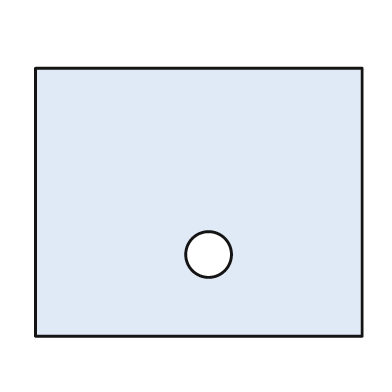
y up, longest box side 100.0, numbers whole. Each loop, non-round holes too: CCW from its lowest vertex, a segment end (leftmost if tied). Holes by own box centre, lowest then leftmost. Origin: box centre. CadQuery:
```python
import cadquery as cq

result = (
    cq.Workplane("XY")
    .moveTo(-50.0, -41.0)
    .lineTo(50.0, -41.0)
    .lineTo(50.0, 41.0)
    .lineTo(-50.0, 41.0)
    .close()
    .moveTo(3.0, -16.0)
    .circle(7.0)
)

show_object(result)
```